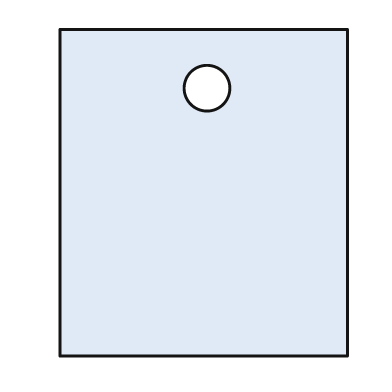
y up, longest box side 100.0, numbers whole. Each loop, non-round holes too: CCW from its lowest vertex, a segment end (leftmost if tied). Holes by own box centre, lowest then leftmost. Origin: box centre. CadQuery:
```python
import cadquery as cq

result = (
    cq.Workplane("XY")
    .moveTo(-44.0, -50.0)
    .lineTo(44.0, -50.0)
    .lineTo(44.0, 50.0)
    .lineTo(-44.0, 50.0)
    .close()
    .moveTo(1.0, 32.0)
    .circle(7.0)
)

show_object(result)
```